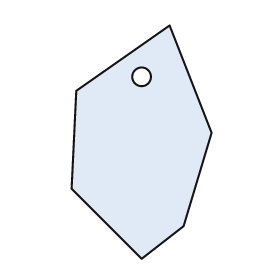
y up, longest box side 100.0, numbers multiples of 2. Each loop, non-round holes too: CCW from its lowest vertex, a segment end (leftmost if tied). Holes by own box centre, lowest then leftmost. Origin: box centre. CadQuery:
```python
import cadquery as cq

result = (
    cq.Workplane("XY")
    .moveTo(0.0, -50.0)
    .lineTo(18.0, -36.0)
    .lineTo(30.0, 4.0)
    .lineTo(12.0, 50.0)
    .lineTo(-28.0, 22.0)
    .lineTo(-30.0, -20.0)
    .close()
    .moveTo(0.0, 28.0)
    .circle(4.0)
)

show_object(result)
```